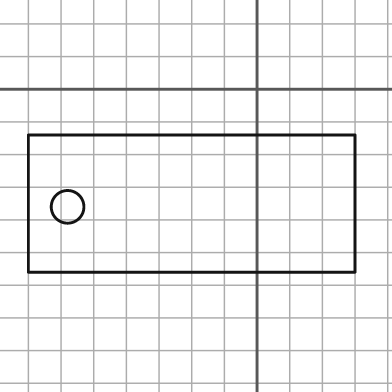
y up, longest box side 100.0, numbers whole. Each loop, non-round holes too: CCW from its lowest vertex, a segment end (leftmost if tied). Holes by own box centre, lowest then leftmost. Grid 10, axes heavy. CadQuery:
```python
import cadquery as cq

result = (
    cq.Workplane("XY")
    .moveTo(-70.0, -56.0)
    .lineTo(30.0, -56.0)
    .lineTo(30.0, -14.0)
    .lineTo(-70.0, -14.0)
    .close()
    .moveTo(-58.0, -36.0)
    .circle(5.0)
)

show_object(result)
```